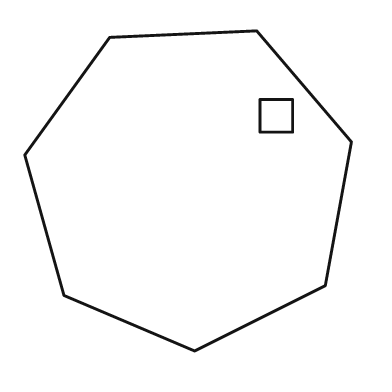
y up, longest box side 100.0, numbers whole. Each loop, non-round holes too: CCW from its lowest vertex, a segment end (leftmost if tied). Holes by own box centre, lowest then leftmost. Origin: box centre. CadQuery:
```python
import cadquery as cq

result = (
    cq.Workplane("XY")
    .moveTo(2.0, -49.0)
    .lineTo(42.0, -29.0)
    .lineTo(50.0, 15.0)
    .lineTo(21.0, 49.0)
    .lineTo(-24.0, 47.0)
    .lineTo(-50.0, 11.0)
    .lineTo(-38.0, -32.0)
    .close()
    .moveTo(22.0, 18.0)
    .lineTo(32.0, 18.0)
    .lineTo(32.0, 28.0)
    .lineTo(22.0, 28.0)
    .close()
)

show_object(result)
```